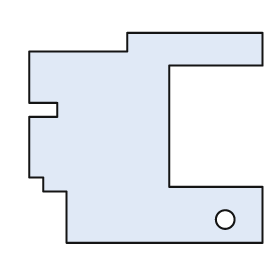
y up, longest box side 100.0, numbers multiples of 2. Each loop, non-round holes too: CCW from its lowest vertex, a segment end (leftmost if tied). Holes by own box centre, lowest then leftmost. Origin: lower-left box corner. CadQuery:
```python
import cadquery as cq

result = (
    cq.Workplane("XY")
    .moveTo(16.0, 0.0)
    .lineTo(100.0, 0.0)
    .lineTo(100.0, 24.0)
    .lineTo(60.0, 24.0)
    .lineTo(60.0, 76.0)
    .lineTo(100.0, 76.0)
    .lineTo(100.0, 90.0)
    .lineTo(42.0, 90.0)
    .lineTo(42.0, 82.0)
    .lineTo(0.0, 82.0)
    .lineTo(0.0, 60.0)
    .lineTo(12.0, 60.0)
    .lineTo(12.0, 54.0)
    .lineTo(0.0, 54.0)
    .lineTo(0.0, 28.0)
    .lineTo(6.0, 28.0)
    .lineTo(6.0, 22.0)
    .lineTo(16.0, 22.0)
    .close()
    .moveTo(84.0, 10.0)
    .circle(4.0)
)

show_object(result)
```